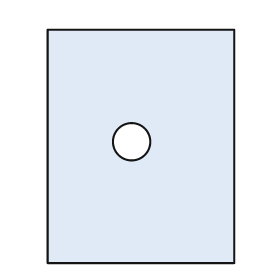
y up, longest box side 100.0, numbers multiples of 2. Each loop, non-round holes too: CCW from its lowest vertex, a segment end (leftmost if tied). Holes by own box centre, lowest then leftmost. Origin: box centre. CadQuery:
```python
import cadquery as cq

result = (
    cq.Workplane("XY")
    .moveTo(-40.0, -50.0)
    .lineTo(40.0, -50.0)
    .lineTo(40.0, 50.0)
    .lineTo(-40.0, 50.0)
    .close()
    .moveTo(-4.0, 2.0)
    .circle(8.0)
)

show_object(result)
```